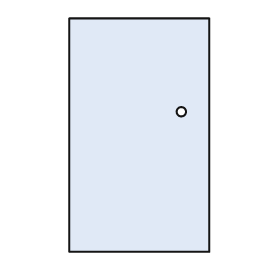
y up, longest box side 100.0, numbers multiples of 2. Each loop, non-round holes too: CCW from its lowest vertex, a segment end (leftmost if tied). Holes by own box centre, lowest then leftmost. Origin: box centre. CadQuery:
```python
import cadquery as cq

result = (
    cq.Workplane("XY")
    .moveTo(-30.0, -50.0)
    .lineTo(30.0, -50.0)
    .lineTo(30.0, 50.0)
    .lineTo(-30.0, 50.0)
    .close()
    .moveTo(18.0, 10.0)
    .circle(2.0)
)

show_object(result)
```